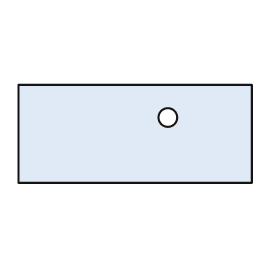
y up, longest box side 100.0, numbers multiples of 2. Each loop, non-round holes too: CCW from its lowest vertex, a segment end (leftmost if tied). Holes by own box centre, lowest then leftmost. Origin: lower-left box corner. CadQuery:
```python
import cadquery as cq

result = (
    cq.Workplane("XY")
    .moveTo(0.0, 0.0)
    .lineTo(100.0, 0.0)
    .lineTo(100.0, 42.0)
    .lineTo(0.0, 42.0)
    .close()
    .moveTo(64.0, 28.0)
    .circle(4.0)
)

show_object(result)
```